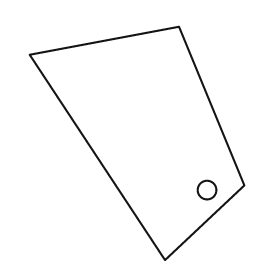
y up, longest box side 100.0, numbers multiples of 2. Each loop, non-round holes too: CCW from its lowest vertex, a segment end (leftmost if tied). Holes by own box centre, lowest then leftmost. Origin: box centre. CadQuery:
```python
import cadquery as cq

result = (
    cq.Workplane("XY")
    .moveTo(12.0, -50.0)
    .lineTo(46.0, -18.0)
    .lineTo(18.0, 50.0)
    .lineTo(-46.0, 38.0)
    .close()
    .moveTo(30.0, -20.0)
    .circle(4.0)
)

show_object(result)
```